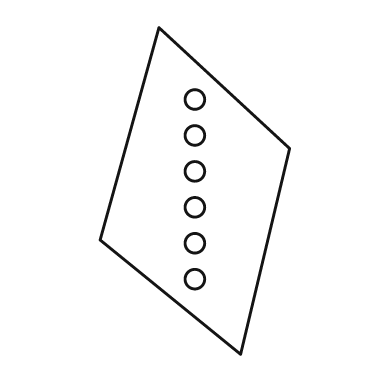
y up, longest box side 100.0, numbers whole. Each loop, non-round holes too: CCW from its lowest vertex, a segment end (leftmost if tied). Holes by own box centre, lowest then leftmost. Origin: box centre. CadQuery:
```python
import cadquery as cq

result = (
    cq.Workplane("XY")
    .moveTo(14.0, -50.0)
    .lineTo(29.0, 13.0)
    .lineTo(-11.0, 50.0)
    .lineTo(-29.0, -15.0)
    .close()
    .moveTo(0.0, -27.0)
    .circle(3.0)
    .moveTo(0.0, -16.0)
    .circle(3.0)
    .moveTo(0.0, -5.0)
    .circle(3.0)
    .moveTo(0.0, 6.0)
    .circle(3.0)
    .moveTo(0.0, 17.0)
    .circle(3.0)
    .moveTo(0.0, 28.0)
    .circle(3.0)
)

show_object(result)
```